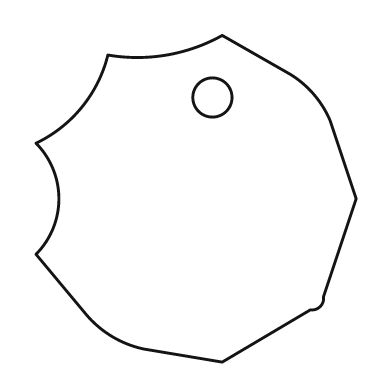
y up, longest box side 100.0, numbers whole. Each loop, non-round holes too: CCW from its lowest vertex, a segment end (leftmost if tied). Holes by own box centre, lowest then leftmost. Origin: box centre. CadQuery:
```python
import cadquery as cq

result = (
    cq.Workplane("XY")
    .moveTo(8.0, -50.0)
    .lineTo(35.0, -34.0)
    .threePointArc((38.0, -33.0), (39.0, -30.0))
    .lineTo(49.0, 0.0)
    .lineTo(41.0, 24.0)
    .threePointArc((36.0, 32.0), (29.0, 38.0))
    .lineTo(8.0, 50.0)
    .threePointArc((-9.0, 44.0), (-27.0, 44.0))
    .threePointArc((-35.0, 28.0), (-49.0, 17.0))
    .threePointArc((-42.0, 0.0), (-49.0, -17.0))
    .lineTo(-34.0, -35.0)
    .threePointArc((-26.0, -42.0), (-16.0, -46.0))
    .close()
    .moveTo(5.0, 31.0)
    .circle(6.0)
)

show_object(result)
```